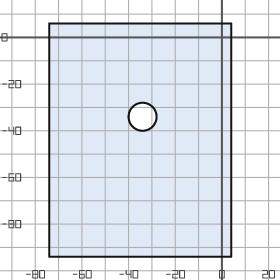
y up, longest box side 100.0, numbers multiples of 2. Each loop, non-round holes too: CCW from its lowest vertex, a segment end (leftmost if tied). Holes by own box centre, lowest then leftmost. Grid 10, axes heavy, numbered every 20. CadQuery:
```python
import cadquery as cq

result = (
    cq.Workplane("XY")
    .moveTo(-74.0, -94.0)
    .lineTo(4.0, -94.0)
    .lineTo(4.0, 6.0)
    .lineTo(-74.0, 6.0)
    .close()
    .moveTo(-34.0, -34.0)
    .circle(6.0)
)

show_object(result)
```